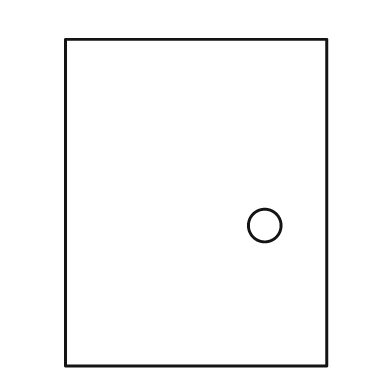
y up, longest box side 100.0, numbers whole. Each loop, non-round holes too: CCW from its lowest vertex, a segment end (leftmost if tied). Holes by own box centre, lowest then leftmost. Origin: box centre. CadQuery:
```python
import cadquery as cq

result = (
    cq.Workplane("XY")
    .moveTo(-40.0, -50.0)
    .lineTo(40.0, -50.0)
    .lineTo(40.0, 50.0)
    .lineTo(-40.0, 50.0)
    .close()
    .moveTo(21.0, -7.0)
    .circle(5.0)
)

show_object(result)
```